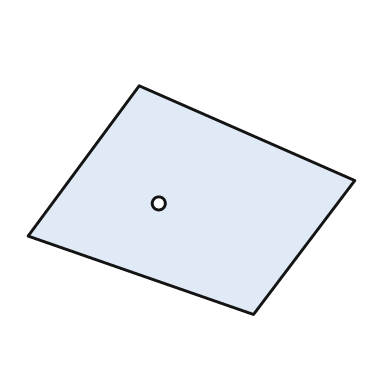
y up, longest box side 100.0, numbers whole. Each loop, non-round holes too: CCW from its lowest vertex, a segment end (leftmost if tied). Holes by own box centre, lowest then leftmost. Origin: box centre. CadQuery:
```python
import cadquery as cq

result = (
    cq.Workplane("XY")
    .moveTo(19.0, -35.0)
    .lineTo(50.0, 6.0)
    .lineTo(-16.0, 35.0)
    .lineTo(-50.0, -11.0)
    .close()
    .moveTo(-10.0, -1.0)
    .circle(2.0)
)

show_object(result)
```